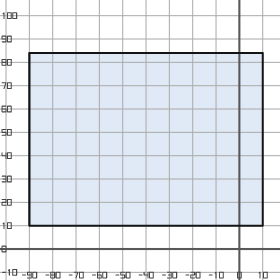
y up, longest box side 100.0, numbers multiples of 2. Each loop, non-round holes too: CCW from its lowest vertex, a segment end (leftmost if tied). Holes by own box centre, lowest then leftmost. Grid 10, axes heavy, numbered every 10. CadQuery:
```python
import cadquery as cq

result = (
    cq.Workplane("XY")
    .moveTo(-90.0, 10.0)
    .lineTo(10.0, 10.0)
    .lineTo(10.0, 84.0)
    .lineTo(-90.0, 84.0)
    .close()
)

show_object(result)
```